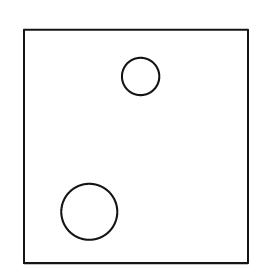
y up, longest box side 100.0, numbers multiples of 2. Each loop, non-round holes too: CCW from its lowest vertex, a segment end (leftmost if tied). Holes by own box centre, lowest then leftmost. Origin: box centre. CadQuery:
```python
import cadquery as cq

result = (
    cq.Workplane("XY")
    .moveTo(-48.0, -50.0)
    .lineTo(48.0, -50.0)
    .lineTo(48.0, 50.0)
    .lineTo(-48.0, 50.0)
    .close()
    .moveTo(-20.0, -28.0)
    .circle(12.0)
    .moveTo(2.0, 30.0)
    .circle(8.0)
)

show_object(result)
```